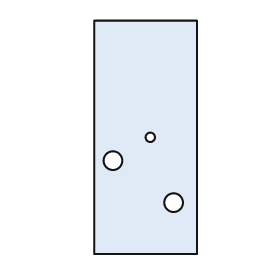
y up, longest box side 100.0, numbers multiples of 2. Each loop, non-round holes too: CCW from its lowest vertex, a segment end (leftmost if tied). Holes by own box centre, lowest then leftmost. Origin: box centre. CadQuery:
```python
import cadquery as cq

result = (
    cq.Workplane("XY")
    .moveTo(-22.0, -50.0)
    .lineTo(22.0, -50.0)
    .lineTo(22.0, 50.0)
    .lineTo(-22.0, 50.0)
    .close()
    .moveTo(12.0, -28.0)
    .circle(4.0)
    .moveTo(-14.0, -10.0)
    .circle(4.0)
    .moveTo(2.0, 0.0)
    .circle(2.0)
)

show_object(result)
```